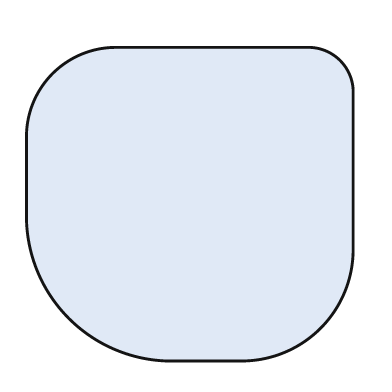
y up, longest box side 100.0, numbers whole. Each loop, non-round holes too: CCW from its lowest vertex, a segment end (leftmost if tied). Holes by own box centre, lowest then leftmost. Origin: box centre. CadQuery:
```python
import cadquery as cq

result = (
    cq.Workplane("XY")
    .moveTo(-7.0, -48.0)
    .lineTo(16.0, -48.0)
    .threePointArc((40.0, -38.0), (50.0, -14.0))
    .lineTo(50.0, 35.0)
    .threePointArc((46.0, 44.0), (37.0, 48.0))
    .lineTo(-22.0, 48.0)
    .threePointArc((-42.0, 40.0), (-50.0, 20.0))
    .lineTo(-50.0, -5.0)
    .threePointArc((-37.0, -35.0), (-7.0, -48.0))
    .close()
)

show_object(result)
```